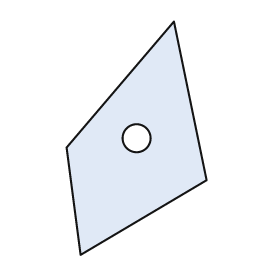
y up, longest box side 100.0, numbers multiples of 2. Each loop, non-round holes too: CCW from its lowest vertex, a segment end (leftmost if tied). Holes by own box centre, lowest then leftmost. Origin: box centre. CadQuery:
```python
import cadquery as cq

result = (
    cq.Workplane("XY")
    .moveTo(-24.0, -50.0)
    .lineTo(30.0, -18.0)
    .lineTo(16.0, 50.0)
    .lineTo(-30.0, -4.0)
    .close()
    .moveTo(0.0, 0.0)
    .circle(6.0)
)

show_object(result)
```